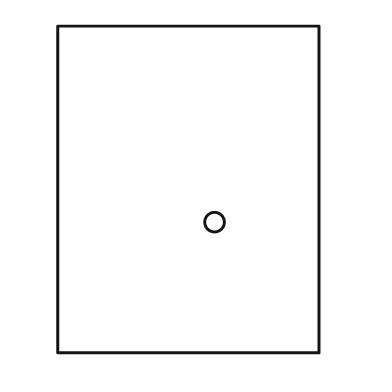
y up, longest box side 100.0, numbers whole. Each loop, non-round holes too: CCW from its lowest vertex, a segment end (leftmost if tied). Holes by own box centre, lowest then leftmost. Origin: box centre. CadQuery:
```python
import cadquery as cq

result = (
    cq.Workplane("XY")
    .moveTo(-40.0, -50.0)
    .lineTo(40.0, -50.0)
    .lineTo(40.0, 50.0)
    .lineTo(-40.0, 50.0)
    .close()
    .moveTo(8.0, -10.0)
    .circle(3.0)
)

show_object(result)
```